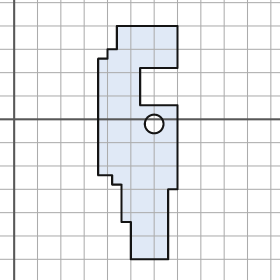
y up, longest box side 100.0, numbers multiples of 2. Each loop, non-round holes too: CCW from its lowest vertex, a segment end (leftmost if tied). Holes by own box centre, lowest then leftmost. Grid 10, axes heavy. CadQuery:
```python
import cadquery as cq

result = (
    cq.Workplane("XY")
    .moveTo(50.0, -60.0)
    .lineTo(66.0, -60.0)
    .lineTo(66.0, -30.0)
    .lineTo(70.0, -30.0)
    .lineTo(70.0, 6.0)
    .lineTo(54.0, 6.0)
    .lineTo(54.0, 22.0)
    .lineTo(70.0, 22.0)
    .lineTo(70.0, 40.0)
    .lineTo(44.0, 40.0)
    .lineTo(44.0, 30.0)
    .lineTo(40.0, 30.0)
    .lineTo(40.0, 26.0)
    .lineTo(36.0, 26.0)
    .lineTo(36.0, -24.0)
    .lineTo(42.0, -24.0)
    .lineTo(42.0, -28.0)
    .lineTo(46.0, -28.0)
    .lineTo(46.0, -44.0)
    .lineTo(50.0, -44.0)
    .close()
    .moveTo(60.0, -2.0)
    .circle(4.0)
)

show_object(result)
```